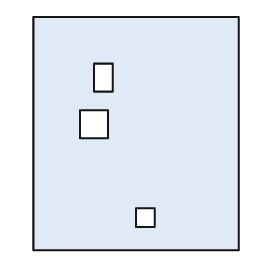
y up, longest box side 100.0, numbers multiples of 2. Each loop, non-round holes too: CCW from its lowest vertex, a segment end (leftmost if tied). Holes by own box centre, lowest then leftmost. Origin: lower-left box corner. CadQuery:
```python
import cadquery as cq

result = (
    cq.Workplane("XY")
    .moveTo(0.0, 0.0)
    .lineTo(88.0, 0.0)
    .lineTo(88.0, 100.0)
    .lineTo(0.0, 100.0)
    .close()
    .moveTo(44.0, 10.0)
    .lineTo(52.0, 10.0)
    .lineTo(52.0, 18.0)
    .lineTo(44.0, 18.0)
    .close()
    .moveTo(20.0, 48.0)
    .lineTo(32.0, 48.0)
    .lineTo(32.0, 60.0)
    .lineTo(20.0, 60.0)
    .close()
    .moveTo(26.0, 68.0)
    .lineTo(34.0, 68.0)
    .lineTo(34.0, 80.0)
    .lineTo(26.0, 80.0)
    .close()
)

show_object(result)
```